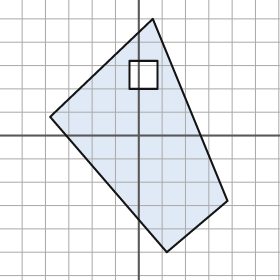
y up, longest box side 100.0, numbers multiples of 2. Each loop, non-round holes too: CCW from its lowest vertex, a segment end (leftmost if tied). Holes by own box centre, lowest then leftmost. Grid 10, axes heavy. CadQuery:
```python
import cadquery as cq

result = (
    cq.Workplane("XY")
    .moveTo(12.0, -50.0)
    .lineTo(38.0, -28.0)
    .lineTo(6.0, 50.0)
    .lineTo(-38.0, 8.0)
    .close()
    .moveTo(-4.0, 20.0)
    .lineTo(8.0, 20.0)
    .lineTo(8.0, 32.0)
    .lineTo(-4.0, 32.0)
    .close()
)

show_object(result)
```